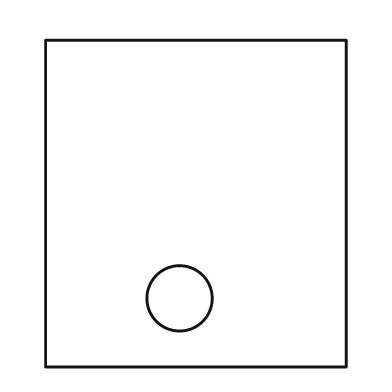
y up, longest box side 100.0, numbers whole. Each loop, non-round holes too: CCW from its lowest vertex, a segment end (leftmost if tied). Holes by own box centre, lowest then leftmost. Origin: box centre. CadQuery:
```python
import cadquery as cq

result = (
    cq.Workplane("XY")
    .moveTo(-46.0, -50.0)
    .lineTo(46.0, -50.0)
    .lineTo(46.0, 50.0)
    .lineTo(-46.0, 50.0)
    .close()
    .moveTo(-5.0, -29.0)
    .circle(10.0)
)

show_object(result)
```